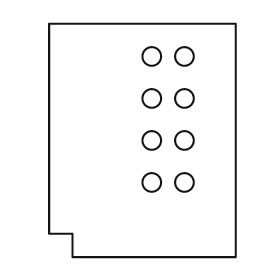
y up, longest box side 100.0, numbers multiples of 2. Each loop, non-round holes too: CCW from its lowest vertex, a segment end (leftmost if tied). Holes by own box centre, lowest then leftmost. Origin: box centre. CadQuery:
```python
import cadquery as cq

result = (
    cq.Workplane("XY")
    .moveTo(-30.0, -50.0)
    .lineTo(40.0, -50.0)
    .lineTo(40.0, 50.0)
    .lineTo(-40.0, 50.0)
    .lineTo(-40.0, -40.0)
    .lineTo(-30.0, -40.0)
    .close()
    .moveTo(4.0, -18.0)
    .circle(4.0)
    .moveTo(18.0, -18.0)
    .circle(4.0)
    .moveTo(4.0, 0.0)
    .circle(4.0)
    .moveTo(18.0, 0.0)
    .circle(4.0)
    .moveTo(4.0, 18.0)
    .circle(4.0)
    .moveTo(18.0, 18.0)
    .circle(4.0)
    .moveTo(4.0, 36.0)
    .circle(4.0)
    .moveTo(18.0, 36.0)
    .circle(4.0)
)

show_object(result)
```